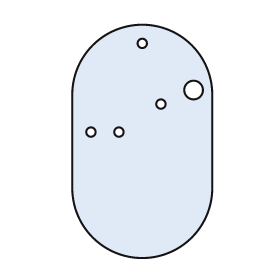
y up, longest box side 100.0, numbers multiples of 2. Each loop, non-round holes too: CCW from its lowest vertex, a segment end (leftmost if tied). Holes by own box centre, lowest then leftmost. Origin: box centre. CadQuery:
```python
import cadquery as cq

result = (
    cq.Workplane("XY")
    .moveTo(-30.0, -20.0)
    .threePointArc((0.0, -50.0), (30.0, -20.0))
    .lineTo(30.0, 20.0)
    .threePointArc((0.0, 50.0), (-30.0, 20.0))
    .close()
    .moveTo(-22.0, 4.0)
    .circle(2.0)
    .moveTo(-10.0, 4.0)
    .circle(2.0)
    .moveTo(8.0, 16.0)
    .circle(2.0)
    .moveTo(22.0, 22.0)
    .circle(4.0)
    .moveTo(0.0, 42.0)
    .circle(2.0)
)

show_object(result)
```